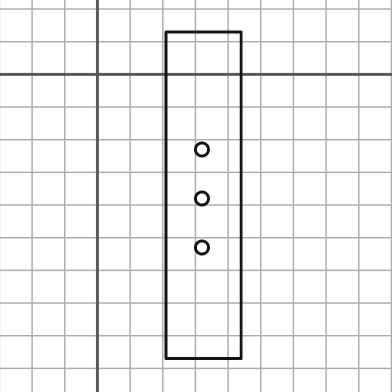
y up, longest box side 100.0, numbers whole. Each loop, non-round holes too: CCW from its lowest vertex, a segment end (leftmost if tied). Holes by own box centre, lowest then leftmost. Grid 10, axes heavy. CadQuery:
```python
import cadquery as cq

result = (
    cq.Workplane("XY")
    .moveTo(21.0, -87.0)
    .lineTo(44.0, -87.0)
    .lineTo(44.0, 13.0)
    .lineTo(21.0, 13.0)
    .close()
    .moveTo(32.0, -53.0)
    .circle(2.0)
    .moveTo(32.0, -38.0)
    .circle(2.0)
    .moveTo(32.0, -23.0)
    .circle(2.0)
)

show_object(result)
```